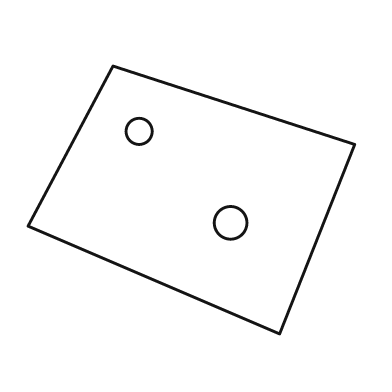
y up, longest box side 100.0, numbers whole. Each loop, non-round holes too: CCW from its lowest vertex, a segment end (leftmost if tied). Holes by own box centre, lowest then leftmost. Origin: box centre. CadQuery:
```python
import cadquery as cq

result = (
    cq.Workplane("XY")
    .moveTo(27.0, -41.0)
    .lineTo(50.0, 17.0)
    .lineTo(-24.0, 41.0)
    .lineTo(-50.0, -8.0)
    .close()
    .moveTo(12.0, -7.0)
    .circle(5.0)
    .moveTo(-16.0, 21.0)
    .circle(4.0)
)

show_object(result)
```